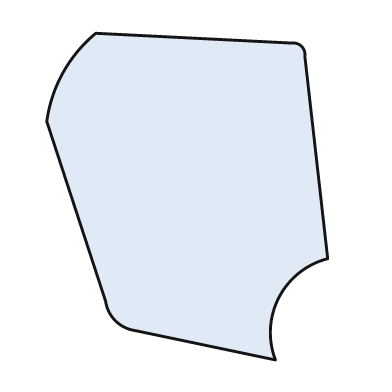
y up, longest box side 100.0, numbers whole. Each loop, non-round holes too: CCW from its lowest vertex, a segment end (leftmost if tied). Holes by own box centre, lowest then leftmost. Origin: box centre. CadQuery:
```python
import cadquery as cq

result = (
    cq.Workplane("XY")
    .moveTo(27.0, -50.0)
    .threePointArc((28.0, -31.0), (43.0, -19.0))
    .lineTo(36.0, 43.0)
    .threePointArc((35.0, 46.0), (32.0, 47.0))
    .lineTo(-28.0, 50.0)
    .threePointArc((-38.0, 38.0), (-43.0, 23.0))
    .lineTo(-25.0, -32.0)
    .threePointArc((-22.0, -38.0), (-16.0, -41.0))
    .close()
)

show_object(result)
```